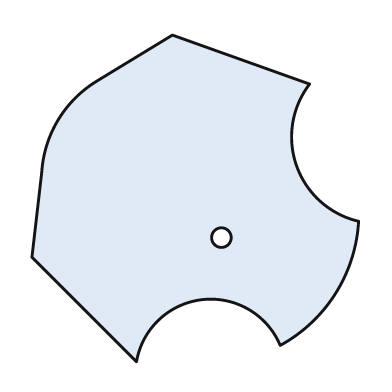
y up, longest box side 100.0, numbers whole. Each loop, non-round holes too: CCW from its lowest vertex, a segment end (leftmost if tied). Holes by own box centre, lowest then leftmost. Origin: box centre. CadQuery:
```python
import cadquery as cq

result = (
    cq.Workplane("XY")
    .moveTo(-18.0, -50.0)
    .threePointArc((2.0, -31.0), (26.0, -45.0))
    .threePointArc((43.0, -29.0), (50.0, -7.0))
    .threePointArc((31.0, 10.0), (35.0, 35.0))
    .lineTo(-7.0, 50.0)
    .lineTo(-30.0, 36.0)
    .threePointArc((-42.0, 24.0), (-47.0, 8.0))
    .lineTo(-50.0, -18.0)
    .close()
    .moveTo(8.0, -12.0)
    .circle(3.0)
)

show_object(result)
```